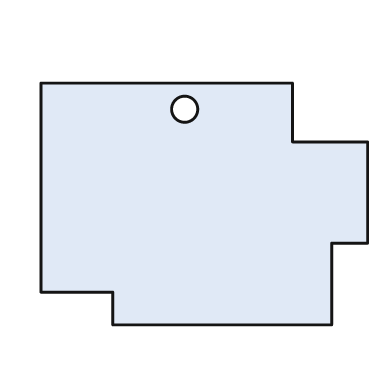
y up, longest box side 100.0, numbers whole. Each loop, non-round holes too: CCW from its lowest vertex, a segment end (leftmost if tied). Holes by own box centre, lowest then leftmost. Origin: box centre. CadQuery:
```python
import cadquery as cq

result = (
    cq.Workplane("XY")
    .moveTo(-28.0, -37.0)
    .lineTo(39.0, -37.0)
    .lineTo(39.0, -12.0)
    .lineTo(50.0, -12.0)
    .lineTo(50.0, 19.0)
    .lineTo(27.0, 19.0)
    .lineTo(27.0, 37.0)
    .lineTo(-50.0, 37.0)
    .lineTo(-50.0, -27.0)
    .lineTo(-28.0, -27.0)
    .close()
    .moveTo(-6.0, 29.0)
    .circle(4.0)
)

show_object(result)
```